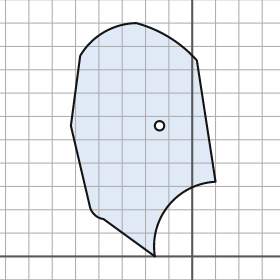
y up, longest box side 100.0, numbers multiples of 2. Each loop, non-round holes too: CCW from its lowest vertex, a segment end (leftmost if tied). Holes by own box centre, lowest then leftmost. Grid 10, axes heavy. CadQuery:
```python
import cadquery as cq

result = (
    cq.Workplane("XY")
    .moveTo(-16.0, 0.0)
    .threePointArc((-10.0, 22.0), (10.0, 32.0))
    .lineTo(2.0, 84.0)
    .threePointArc((-10.0, 94.0), (-24.0, 100.0))
    .threePointArc((-38.0, 96.0), (-48.0, 86.0))
    .lineTo(-52.0, 56.0)
    .lineTo(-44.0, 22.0)
    .threePointArc((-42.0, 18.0), (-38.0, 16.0))
    .close()
    .moveTo(-14.0, 56.0)
    .circle(2.0)
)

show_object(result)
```